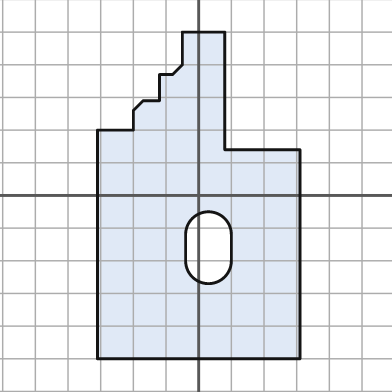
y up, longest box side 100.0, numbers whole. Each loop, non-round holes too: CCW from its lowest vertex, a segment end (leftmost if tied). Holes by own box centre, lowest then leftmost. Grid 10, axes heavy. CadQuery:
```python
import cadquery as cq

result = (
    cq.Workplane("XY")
    .moveTo(-31.0, -50.0)
    .lineTo(31.0, -50.0)
    .lineTo(31.0, 14.0)
    .lineTo(8.0, 14.0)
    .lineTo(8.0, 50.0)
    .lineTo(-5.0, 50.0)
    .lineTo(-5.0, 40.0)
    .lineTo(-8.0, 37.0)
    .lineTo(-12.0, 37.0)
    .lineTo(-12.0, 29.0)
    .lineTo(-17.0, 29.0)
    .lineTo(-20.0, 26.0)
    .lineTo(-20.0, 20.0)
    .lineTo(-31.0, 20.0)
    .close()
    .moveTo(-4.0, -20.0)
    .threePointArc((3.0, -27.0), (10.0, -20.0))
    .lineTo(10.0, -12.0)
    .threePointArc((3.0, -5.0), (-4.0, -12.0))
    .close()
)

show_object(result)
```